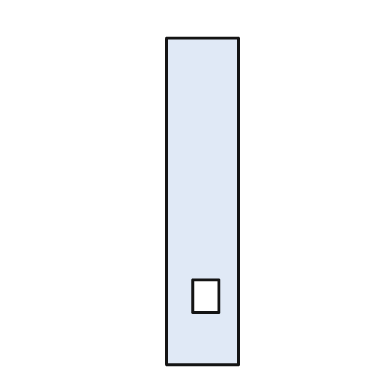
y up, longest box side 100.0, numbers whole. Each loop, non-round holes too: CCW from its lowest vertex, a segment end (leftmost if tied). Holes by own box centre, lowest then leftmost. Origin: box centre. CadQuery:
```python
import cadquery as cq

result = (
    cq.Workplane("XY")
    .moveTo(-11.0, -50.0)
    .lineTo(11.0, -50.0)
    .lineTo(11.0, 50.0)
    .lineTo(-11.0, 50.0)
    .close()
    .moveTo(-3.0, -34.0)
    .lineTo(5.0, -34.0)
    .lineTo(5.0, -24.0)
    .lineTo(-3.0, -24.0)
    .close()
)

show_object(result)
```